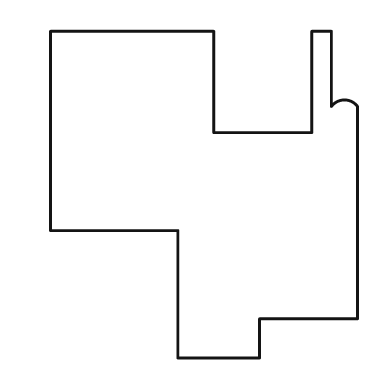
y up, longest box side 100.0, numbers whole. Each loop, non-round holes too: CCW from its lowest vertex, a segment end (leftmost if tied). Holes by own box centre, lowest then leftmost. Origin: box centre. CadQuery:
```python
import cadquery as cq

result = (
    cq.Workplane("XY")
    .moveTo(-8.0, -50.0)
    .lineTo(17.0, -50.0)
    .lineTo(17.0, -38.0)
    .lineTo(47.0, -38.0)
    .lineTo(47.0, 27.0)
    .threePointArc((43.0, 29.0), (39.0, 27.0))
    .lineTo(39.0, 50.0)
    .lineTo(33.0, 50.0)
    .lineTo(33.0, 19.0)
    .lineTo(3.0, 19.0)
    .lineTo(3.0, 50.0)
    .lineTo(-47.0, 50.0)
    .lineTo(-47.0, -11.0)
    .lineTo(-8.0, -11.0)
    .close()
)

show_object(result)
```